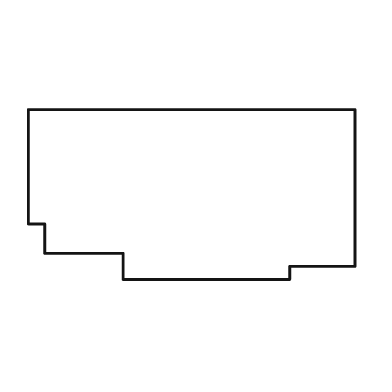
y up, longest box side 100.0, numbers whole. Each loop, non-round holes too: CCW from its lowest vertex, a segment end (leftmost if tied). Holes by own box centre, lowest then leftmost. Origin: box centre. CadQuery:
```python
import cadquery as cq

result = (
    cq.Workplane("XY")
    .moveTo(-21.0, -26.0)
    .lineTo(30.0, -26.0)
    .lineTo(30.0, -22.0)
    .lineTo(50.0, -22.0)
    .lineTo(50.0, 26.0)
    .lineTo(-50.0, 26.0)
    .lineTo(-50.0, -9.0)
    .lineTo(-45.0, -9.0)
    .lineTo(-45.0, -18.0)
    .lineTo(-21.0, -18.0)
    .close()
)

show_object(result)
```